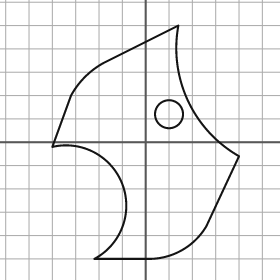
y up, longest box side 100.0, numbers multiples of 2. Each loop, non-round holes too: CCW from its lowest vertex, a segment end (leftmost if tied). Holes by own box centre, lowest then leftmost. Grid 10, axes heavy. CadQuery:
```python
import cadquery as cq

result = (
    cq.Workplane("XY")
    .moveTo(-22.0, -50.0)
    .lineTo(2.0, -50.0)
    .threePointArc((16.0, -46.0), (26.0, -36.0))
    .lineTo(40.0, -6.0)
    .threePointArc((18.0, 18.0), (14.0, 50.0))
    .lineTo(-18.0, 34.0)
    .threePointArc((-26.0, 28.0), (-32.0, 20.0))
    .lineTo(-40.0, -2.0)
    .threePointArc((-10.0, -18.0), (-22.0, -50.0))
    .close()
    .moveTo(10.0, 12.0)
    .circle(6.0)
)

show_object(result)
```